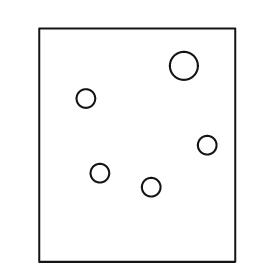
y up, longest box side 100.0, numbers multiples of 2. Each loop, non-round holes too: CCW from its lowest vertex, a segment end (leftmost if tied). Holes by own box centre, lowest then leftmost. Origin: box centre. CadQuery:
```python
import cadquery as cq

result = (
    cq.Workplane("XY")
    .moveTo(-42.0, -50.0)
    .lineTo(42.0, -50.0)
    .lineTo(42.0, 50.0)
    .lineTo(-42.0, 50.0)
    .close()
    .moveTo(6.0, -18.0)
    .circle(4.0)
    .moveTo(-16.0, -12.0)
    .circle(4.0)
    .moveTo(30.0, 0.0)
    .circle(4.0)
    .moveTo(-22.0, 20.0)
    .circle(4.0)
    .moveTo(20.0, 34.0)
    .circle(6.0)
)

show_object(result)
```